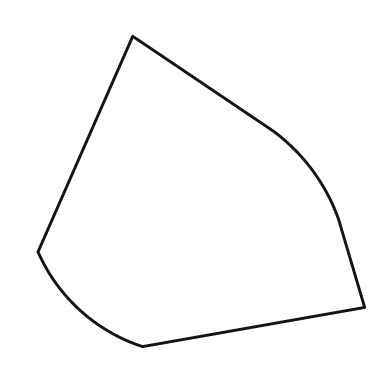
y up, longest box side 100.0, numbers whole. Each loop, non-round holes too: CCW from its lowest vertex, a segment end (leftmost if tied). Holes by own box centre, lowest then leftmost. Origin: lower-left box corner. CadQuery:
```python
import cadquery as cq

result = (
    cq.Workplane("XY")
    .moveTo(32.0, 0.0)
    .lineTo(100.0, 12.0)
    .lineTo(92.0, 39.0)
    .threePointArc((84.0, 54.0), (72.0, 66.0))
    .lineTo(29.0, 95.0)
    .lineTo(0.0, 29.0)
    .threePointArc((13.0, 11.0), (32.0, 0.0))
    .close()
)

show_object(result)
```